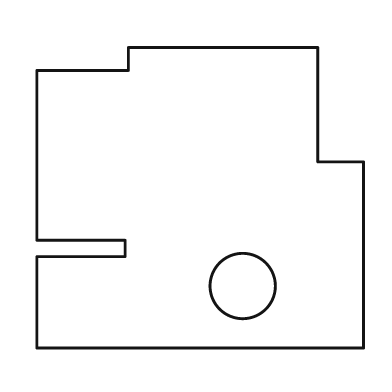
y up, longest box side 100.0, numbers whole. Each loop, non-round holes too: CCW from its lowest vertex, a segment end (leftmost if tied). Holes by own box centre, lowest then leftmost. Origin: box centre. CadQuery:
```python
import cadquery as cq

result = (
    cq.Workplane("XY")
    .moveTo(-50.0, -46.0)
    .lineTo(50.0, -46.0)
    .lineTo(50.0, 11.0)
    .lineTo(36.0, 11.0)
    .lineTo(36.0, 46.0)
    .lineTo(-22.0, 46.0)
    .lineTo(-22.0, 39.0)
    .lineTo(-50.0, 39.0)
    .lineTo(-50.0, -13.0)
    .lineTo(-23.0, -13.0)
    .lineTo(-23.0, -18.0)
    .lineTo(-50.0, -18.0)
    .close()
    .moveTo(13.0, -27.0)
    .circle(10.0)
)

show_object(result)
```